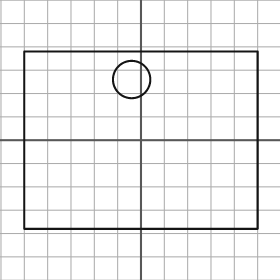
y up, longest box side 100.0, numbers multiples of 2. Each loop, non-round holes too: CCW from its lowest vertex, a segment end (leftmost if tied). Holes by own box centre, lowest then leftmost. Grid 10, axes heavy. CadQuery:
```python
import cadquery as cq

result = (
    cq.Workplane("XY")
    .moveTo(-50.0, -38.0)
    .lineTo(50.0, -38.0)
    .lineTo(50.0, 38.0)
    .lineTo(-50.0, 38.0)
    .close()
    .moveTo(-4.0, 26.0)
    .circle(8.0)
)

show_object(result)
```